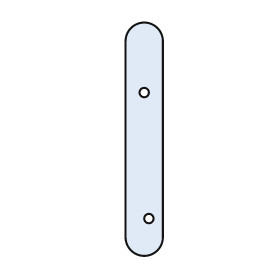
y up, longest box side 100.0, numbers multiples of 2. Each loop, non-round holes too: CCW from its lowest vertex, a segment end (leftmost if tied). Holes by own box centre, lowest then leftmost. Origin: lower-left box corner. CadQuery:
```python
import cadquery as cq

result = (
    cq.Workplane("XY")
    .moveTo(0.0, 8.0)
    .threePointArc((8.0, 0.0), (16.0, 8.0))
    .lineTo(16.0, 92.0)
    .threePointArc((8.0, 100.0), (0.0, 92.0))
    .close()
    .moveTo(10.0, 16.0)
    .circle(2.0)
    .moveTo(8.0, 70.0)
    .circle(2.0)
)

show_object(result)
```